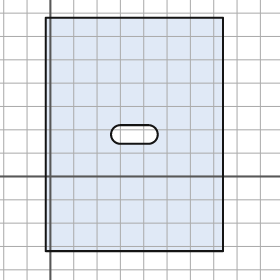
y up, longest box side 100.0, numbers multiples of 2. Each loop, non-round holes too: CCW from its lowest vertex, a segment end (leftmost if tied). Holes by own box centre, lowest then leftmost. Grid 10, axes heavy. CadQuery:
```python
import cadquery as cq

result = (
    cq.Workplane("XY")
    .moveTo(-2.0, -32.0)
    .lineTo(74.0, -32.0)
    .lineTo(74.0, 68.0)
    .lineTo(-2.0, 68.0)
    .close()
    .moveTo(30.0, 14.0)
    .lineTo(42.0, 14.0)
    .threePointArc((46.0, 18.0), (42.0, 22.0))
    .lineTo(30.0, 22.0)
    .threePointArc((26.0, 18.0), (30.0, 14.0))
    .close()
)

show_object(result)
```